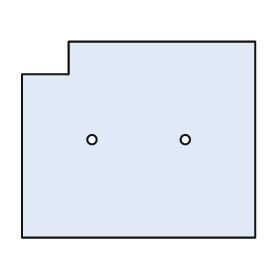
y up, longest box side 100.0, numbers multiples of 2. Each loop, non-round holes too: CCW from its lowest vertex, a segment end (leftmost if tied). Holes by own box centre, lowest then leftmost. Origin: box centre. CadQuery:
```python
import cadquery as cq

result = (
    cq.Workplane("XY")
    .moveTo(-50.0, -42.0)
    .lineTo(50.0, -42.0)
    .lineTo(50.0, 42.0)
    .lineTo(-30.0, 42.0)
    .lineTo(-30.0, 28.0)
    .lineTo(-50.0, 28.0)
    .close()
    .moveTo(-20.0, 0.0)
    .circle(2.0)
    .moveTo(20.0, 0.0)
    .circle(2.0)
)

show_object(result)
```